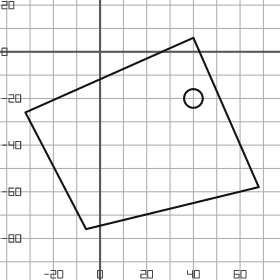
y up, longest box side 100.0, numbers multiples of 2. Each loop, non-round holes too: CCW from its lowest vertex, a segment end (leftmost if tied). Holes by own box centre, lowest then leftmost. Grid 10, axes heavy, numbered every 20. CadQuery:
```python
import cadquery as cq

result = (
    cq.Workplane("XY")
    .moveTo(-6.0, -76.0)
    .lineTo(68.0, -58.0)
    .lineTo(40.0, 6.0)
    .lineTo(-32.0, -26.0)
    .close()
    .moveTo(40.0, -20.0)
    .circle(4.0)
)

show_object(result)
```